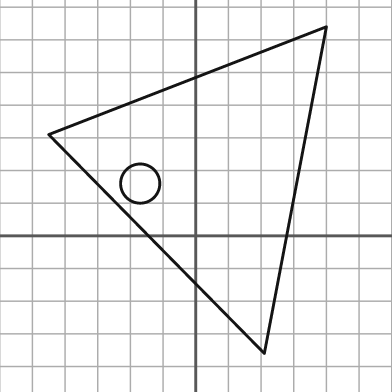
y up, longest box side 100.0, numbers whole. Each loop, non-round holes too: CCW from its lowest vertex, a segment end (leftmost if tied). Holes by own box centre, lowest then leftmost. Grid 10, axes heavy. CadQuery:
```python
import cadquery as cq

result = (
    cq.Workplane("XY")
    .moveTo(21.0, -36.0)
    .lineTo(40.0, 64.0)
    .lineTo(-45.0, 31.0)
    .close()
    .moveTo(-17.0, 16.0)
    .circle(6.0)
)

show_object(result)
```